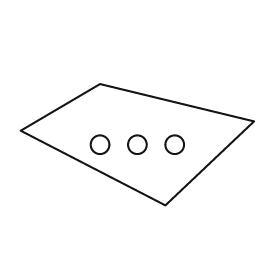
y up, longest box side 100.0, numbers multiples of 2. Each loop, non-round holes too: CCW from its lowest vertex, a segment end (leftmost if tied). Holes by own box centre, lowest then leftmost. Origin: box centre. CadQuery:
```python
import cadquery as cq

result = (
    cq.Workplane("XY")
    .moveTo(12.0, -26.0)
    .lineTo(50.0, 10.0)
    .lineTo(-16.0, 26.0)
    .lineTo(-50.0, 6.0)
    .close()
    .moveTo(-16.0, 0.0)
    .circle(4.0)
    .moveTo(0.0, 0.0)
    .circle(4.0)
    .moveTo(16.0, 0.0)
    .circle(4.0)
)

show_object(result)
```